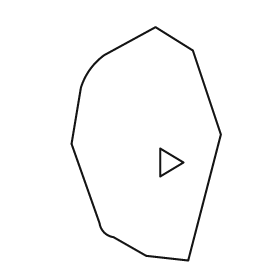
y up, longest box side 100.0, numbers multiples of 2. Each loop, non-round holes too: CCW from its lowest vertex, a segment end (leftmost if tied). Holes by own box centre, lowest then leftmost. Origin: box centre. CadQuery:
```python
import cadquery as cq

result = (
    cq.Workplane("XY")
    .moveTo(18.0, -50.0)
    .lineTo(32.0, 4.0)
    .lineTo(20.0, 40.0)
    .lineTo(4.0, 50.0)
    .lineTo(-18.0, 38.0)
    .threePointArc((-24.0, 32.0), (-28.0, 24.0))
    .lineTo(-32.0, 0.0)
    .lineTo(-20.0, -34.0)
    .threePointArc((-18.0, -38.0), (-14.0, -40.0))
    .lineTo(0.0, -48.0)
    .close()
    .moveTo(6.0, -14.0)
    .lineTo(16.0, -8.0)
    .lineTo(6.0, -2.0)
    .close()
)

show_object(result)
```